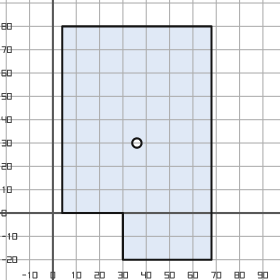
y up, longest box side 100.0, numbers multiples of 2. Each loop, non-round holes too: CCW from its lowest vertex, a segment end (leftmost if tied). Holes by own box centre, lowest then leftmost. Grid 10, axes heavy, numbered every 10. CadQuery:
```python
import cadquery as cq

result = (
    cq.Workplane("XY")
    .moveTo(30.0, -20.0)
    .lineTo(68.0, -20.0)
    .lineTo(68.0, 80.0)
    .lineTo(4.0, 80.0)
    .lineTo(4.0, 0.0)
    .lineTo(30.0, 0.0)
    .close()
    .moveTo(36.0, 30.0)
    .circle(2.0)
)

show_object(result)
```